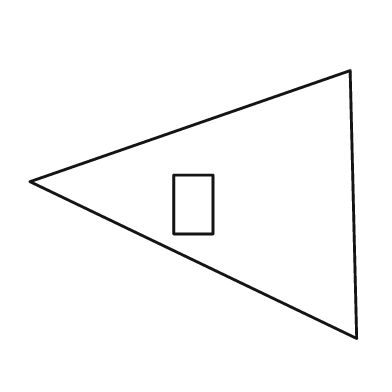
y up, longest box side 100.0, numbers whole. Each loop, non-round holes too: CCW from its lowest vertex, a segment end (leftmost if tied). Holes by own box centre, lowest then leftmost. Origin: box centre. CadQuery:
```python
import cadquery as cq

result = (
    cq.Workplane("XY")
    .moveTo(50.0, -41.0)
    .lineTo(48.0, 41.0)
    .lineTo(-50.0, 7.0)
    .close()
    .moveTo(-6.0, -9.0)
    .lineTo(6.0, -9.0)
    .lineTo(6.0, 9.0)
    .lineTo(-6.0, 9.0)
    .close()
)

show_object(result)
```